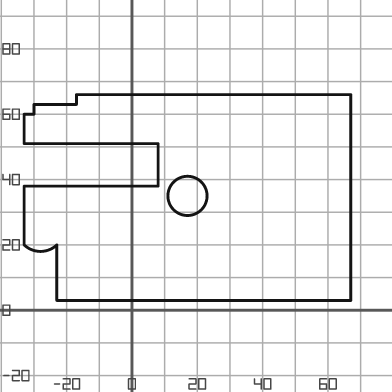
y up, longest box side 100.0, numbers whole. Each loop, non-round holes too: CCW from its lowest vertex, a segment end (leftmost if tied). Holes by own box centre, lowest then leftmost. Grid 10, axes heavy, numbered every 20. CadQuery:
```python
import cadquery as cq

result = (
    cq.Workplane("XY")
    .moveTo(-23.0, 3.0)
    .lineTo(67.0, 3.0)
    .lineTo(67.0, 66.0)
    .lineTo(-17.0, 66.0)
    .lineTo(-17.0, 63.0)
    .lineTo(-30.0, 63.0)
    .lineTo(-30.0, 60.0)
    .lineTo(-33.0, 60.0)
    .lineTo(-33.0, 51.0)
    .lineTo(8.0, 51.0)
    .lineTo(8.0, 38.0)
    .lineTo(-33.0, 38.0)
    .lineTo(-33.0, 20.0)
    .threePointArc((-28.0, 18.0), (-23.0, 20.0))
    .close()
    .moveTo(17.0, 35.0)
    .circle(6.0)
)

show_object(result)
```